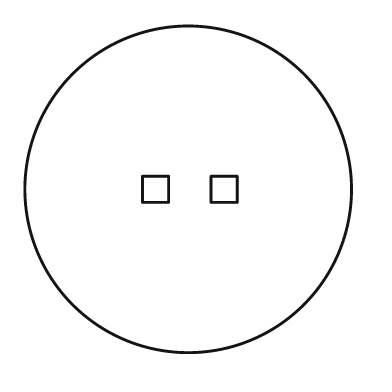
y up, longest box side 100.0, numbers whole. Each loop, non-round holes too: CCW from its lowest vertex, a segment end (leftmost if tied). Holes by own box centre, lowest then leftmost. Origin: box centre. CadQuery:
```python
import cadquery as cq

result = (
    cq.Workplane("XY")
    .moveTo(0.0, 0.0)
    .circle(50.0)
    .moveTo(-14.0, -4.0)
    .lineTo(-6.0, -4.0)
    .lineTo(-6.0, 4.0)
    .lineTo(-14.0, 4.0)
    .close()
    .moveTo(7.0, -4.0)
    .lineTo(15.0, -4.0)
    .lineTo(15.0, 4.0)
    .lineTo(7.0, 4.0)
    .close()
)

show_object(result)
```